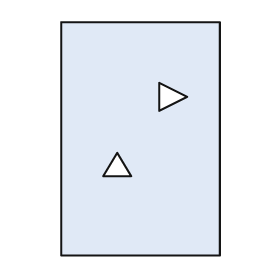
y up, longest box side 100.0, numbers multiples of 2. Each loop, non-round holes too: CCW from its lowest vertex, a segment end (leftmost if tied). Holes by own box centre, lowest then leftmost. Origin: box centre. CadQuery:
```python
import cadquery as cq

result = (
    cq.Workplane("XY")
    .moveTo(-34.0, -50.0)
    .lineTo(34.0, -50.0)
    .lineTo(34.0, 50.0)
    .lineTo(-34.0, 50.0)
    .close()
    .moveTo(-16.0, -16.0)
    .lineTo(-4.0, -16.0)
    .lineTo(-10.0, -6.0)
    .close()
    .moveTo(8.0, 12.0)
    .lineTo(20.0, 18.0)
    .lineTo(8.0, 24.0)
    .close()
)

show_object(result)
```